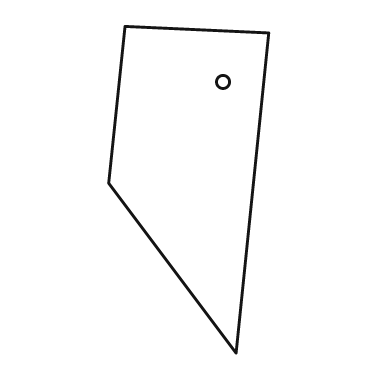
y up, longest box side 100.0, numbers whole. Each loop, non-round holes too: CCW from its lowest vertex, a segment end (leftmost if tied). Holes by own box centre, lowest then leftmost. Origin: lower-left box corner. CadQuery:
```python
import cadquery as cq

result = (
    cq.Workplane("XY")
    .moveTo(39.0, 0.0)
    .lineTo(49.0, 98.0)
    .lineTo(5.0, 100.0)
    .lineTo(0.0, 52.0)
    .close()
    .moveTo(35.0, 83.0)
    .circle(2.0)
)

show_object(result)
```